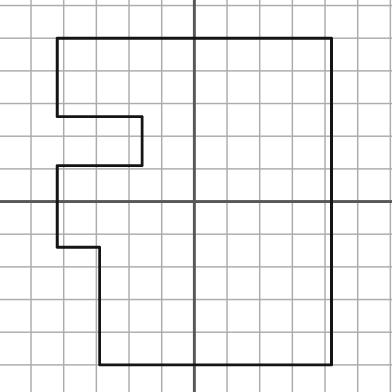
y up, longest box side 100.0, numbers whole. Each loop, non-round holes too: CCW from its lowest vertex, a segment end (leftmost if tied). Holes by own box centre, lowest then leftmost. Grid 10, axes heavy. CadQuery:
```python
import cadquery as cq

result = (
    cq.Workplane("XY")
    .moveTo(-29.0, -50.0)
    .lineTo(42.0, -50.0)
    .lineTo(42.0, 50.0)
    .lineTo(-42.0, 50.0)
    .lineTo(-42.0, 26.0)
    .lineTo(-16.0, 26.0)
    .lineTo(-16.0, 11.0)
    .lineTo(-42.0, 11.0)
    .lineTo(-42.0, -14.0)
    .lineTo(-29.0, -14.0)
    .close()
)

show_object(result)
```